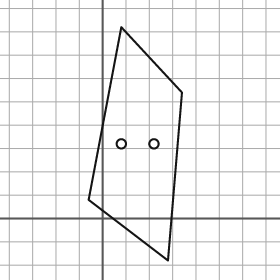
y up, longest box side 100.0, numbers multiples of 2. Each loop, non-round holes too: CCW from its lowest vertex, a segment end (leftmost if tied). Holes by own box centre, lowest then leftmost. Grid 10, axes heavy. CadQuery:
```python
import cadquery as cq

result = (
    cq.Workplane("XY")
    .moveTo(28.0, -18.0)
    .lineTo(34.0, 54.0)
    .lineTo(8.0, 82.0)
    .lineTo(-6.0, 8.0)
    .close()
    .moveTo(8.0, 32.0)
    .circle(2.0)
    .moveTo(22.0, 32.0)
    .circle(2.0)
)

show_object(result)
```